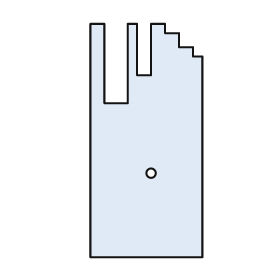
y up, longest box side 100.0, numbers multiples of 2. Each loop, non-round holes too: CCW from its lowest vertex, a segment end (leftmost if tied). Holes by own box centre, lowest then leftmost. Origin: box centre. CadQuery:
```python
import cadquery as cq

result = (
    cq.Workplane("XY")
    .moveTo(-24.0, -50.0)
    .lineTo(24.0, -50.0)
    .lineTo(24.0, 36.0)
    .lineTo(20.0, 36.0)
    .lineTo(20.0, 40.0)
    .lineTo(14.0, 40.0)
    .lineTo(14.0, 46.0)
    .lineTo(8.0, 46.0)
    .lineTo(8.0, 50.0)
    .lineTo(2.0, 50.0)
    .lineTo(2.0, 28.0)
    .lineTo(-4.0, 28.0)
    .lineTo(-4.0, 50.0)
    .lineTo(-8.0, 50.0)
    .lineTo(-8.0, 16.0)
    .lineTo(-18.0, 16.0)
    .lineTo(-18.0, 50.0)
    .lineTo(-24.0, 50.0)
    .close()
    .moveTo(2.0, -14.0)
    .circle(2.0)
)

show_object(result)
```